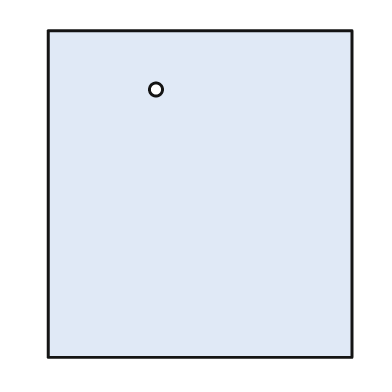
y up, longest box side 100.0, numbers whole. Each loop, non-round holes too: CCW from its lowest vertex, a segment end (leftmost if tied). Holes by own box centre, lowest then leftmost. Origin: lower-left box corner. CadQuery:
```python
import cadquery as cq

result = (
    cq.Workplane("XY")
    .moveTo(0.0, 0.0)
    .lineTo(93.0, 0.0)
    .lineTo(93.0, 100.0)
    .lineTo(0.0, 100.0)
    .close()
    .moveTo(33.0, 82.0)
    .circle(2.0)
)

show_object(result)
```